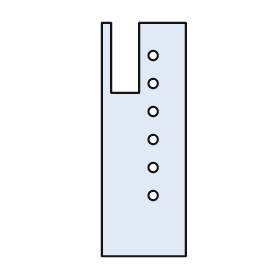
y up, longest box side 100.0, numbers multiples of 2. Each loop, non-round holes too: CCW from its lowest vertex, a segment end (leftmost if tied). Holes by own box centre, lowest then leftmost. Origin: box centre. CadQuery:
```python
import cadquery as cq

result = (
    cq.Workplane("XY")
    .moveTo(-18.0, -50.0)
    .lineTo(18.0, -50.0)
    .lineTo(18.0, 50.0)
    .lineTo(-2.0, 50.0)
    .lineTo(-2.0, 20.0)
    .lineTo(-14.0, 20.0)
    .lineTo(-14.0, 50.0)
    .lineTo(-18.0, 50.0)
    .close()
    .moveTo(4.0, -24.0)
    .circle(2.0)
    .moveTo(4.0, -12.0)
    .circle(2.0)
    .moveTo(4.0, 0.0)
    .circle(2.0)
    .moveTo(4.0, 12.0)
    .circle(2.0)
    .moveTo(4.0, 24.0)
    .circle(2.0)
    .moveTo(4.0, 36.0)
    .circle(2.0)
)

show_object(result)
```